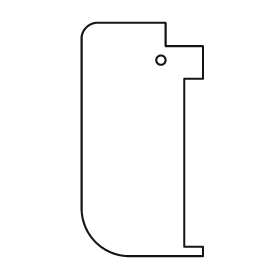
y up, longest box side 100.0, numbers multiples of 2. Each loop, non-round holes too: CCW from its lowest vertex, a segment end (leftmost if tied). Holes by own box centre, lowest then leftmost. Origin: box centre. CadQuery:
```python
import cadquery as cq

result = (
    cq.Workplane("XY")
    .moveTo(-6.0, -50.0)
    .lineTo(26.0, -50.0)
    .lineTo(26.0, -46.0)
    .lineTo(18.0, -46.0)
    .lineTo(18.0, 26.0)
    .lineTo(26.0, 26.0)
    .lineTo(26.0, 40.0)
    .lineTo(10.0, 40.0)
    .lineTo(10.0, 50.0)
    .lineTo(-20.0, 50.0)
    .threePointArc((-24.0, 48.0), (-26.0, 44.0))
    .lineTo(-26.0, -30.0)
    .threePointArc((-20.0, -44.0), (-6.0, -50.0))
    .close()
    .moveTo(8.0, 34.0)
    .circle(2.0)
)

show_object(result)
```